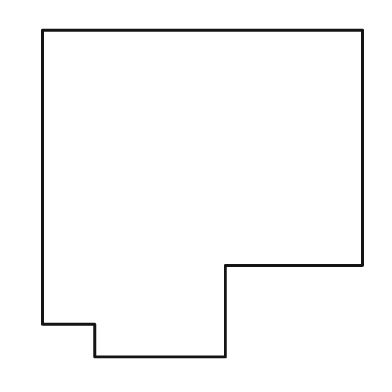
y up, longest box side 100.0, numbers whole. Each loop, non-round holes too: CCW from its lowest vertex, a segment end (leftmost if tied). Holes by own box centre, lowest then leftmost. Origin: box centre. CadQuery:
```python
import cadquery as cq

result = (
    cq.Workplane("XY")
    .moveTo(-33.0, -50.0)
    .lineTo(7.0, -50.0)
    .lineTo(7.0, -22.0)
    .lineTo(49.0, -22.0)
    .lineTo(49.0, 50.0)
    .lineTo(-49.0, 50.0)
    .lineTo(-49.0, -40.0)
    .lineTo(-33.0, -40.0)
    .close()
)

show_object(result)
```